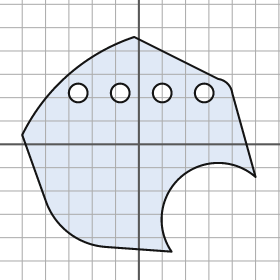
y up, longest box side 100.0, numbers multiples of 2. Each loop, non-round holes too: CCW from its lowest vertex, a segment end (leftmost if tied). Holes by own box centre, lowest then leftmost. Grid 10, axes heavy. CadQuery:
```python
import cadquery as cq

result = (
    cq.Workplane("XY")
    .moveTo(14.0, -46.0)
    .threePointArc((18.0, -14.0), (50.0, -14.0))
    .lineTo(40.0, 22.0)
    .threePointArc((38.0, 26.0), (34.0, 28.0))
    .lineTo(-2.0, 46.0)
    .threePointArc((-30.0, 30.0), (-50.0, 4.0))
    .lineTo(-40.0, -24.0)
    .threePointArc((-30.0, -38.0), (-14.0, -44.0))
    .close()
    .moveTo(-26.0, 22.0)
    .circle(4.0)
    .moveTo(-8.0, 22.0)
    .circle(4.0)
    .moveTo(10.0, 22.0)
    .circle(4.0)
    .moveTo(28.0, 22.0)
    .circle(4.0)
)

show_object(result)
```